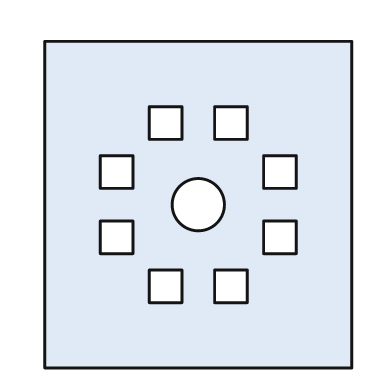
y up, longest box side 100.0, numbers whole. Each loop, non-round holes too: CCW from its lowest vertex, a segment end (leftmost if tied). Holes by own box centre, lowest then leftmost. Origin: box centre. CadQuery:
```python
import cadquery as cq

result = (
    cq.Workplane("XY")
    .moveTo(-47.0, -50.0)
    .lineTo(47.0, -50.0)
    .lineTo(47.0, 50.0)
    .lineTo(-47.0, 50.0)
    .close()
    .moveTo(-15.0, -30.0)
    .lineTo(-5.0, -30.0)
    .lineTo(-5.0, -20.0)
    .lineTo(-15.0, -20.0)
    .close()
    .moveTo(5.0, -30.0)
    .lineTo(15.0, -30.0)
    .lineTo(15.0, -20.0)
    .lineTo(5.0, -20.0)
    .close()
    .moveTo(-30.0, -15.0)
    .lineTo(-20.0, -15.0)
    .lineTo(-20.0, -5.0)
    .lineTo(-30.0, -5.0)
    .close()
    .moveTo(20.0, -15.0)
    .lineTo(30.0, -15.0)
    .lineTo(30.0, -5.0)
    .lineTo(20.0, -5.0)
    .close()
    .moveTo(0.0, 0.0)
    .circle(8.0)
    .moveTo(-30.0, 5.0)
    .lineTo(-20.0, 5.0)
    .lineTo(-20.0, 15.0)
    .lineTo(-30.0, 15.0)
    .close()
    .moveTo(20.0, 5.0)
    .lineTo(30.0, 5.0)
    .lineTo(30.0, 15.0)
    .lineTo(20.0, 15.0)
    .close()
    .moveTo(-15.0, 20.0)
    .lineTo(-5.0, 20.0)
    .lineTo(-5.0, 30.0)
    .lineTo(-15.0, 30.0)
    .close()
    .moveTo(5.0, 20.0)
    .lineTo(15.0, 20.0)
    .lineTo(15.0, 30.0)
    .lineTo(5.0, 30.0)
    .close()
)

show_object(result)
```